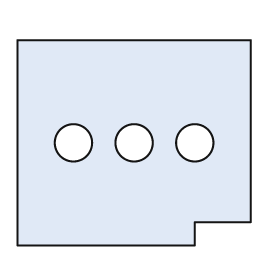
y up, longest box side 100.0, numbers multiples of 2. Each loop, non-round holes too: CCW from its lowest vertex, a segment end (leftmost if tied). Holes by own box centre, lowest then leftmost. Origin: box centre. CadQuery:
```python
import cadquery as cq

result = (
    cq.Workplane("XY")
    .moveTo(-50.0, -44.0)
    .lineTo(26.0, -44.0)
    .lineTo(26.0, -34.0)
    .lineTo(50.0, -34.0)
    .lineTo(50.0, 44.0)
    .lineTo(-50.0, 44.0)
    .close()
    .moveTo(-26.0, 0.0)
    .circle(8.0)
    .moveTo(0.0, 0.0)
    .circle(8.0)
    .moveTo(26.0, 0.0)
    .circle(8.0)
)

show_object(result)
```